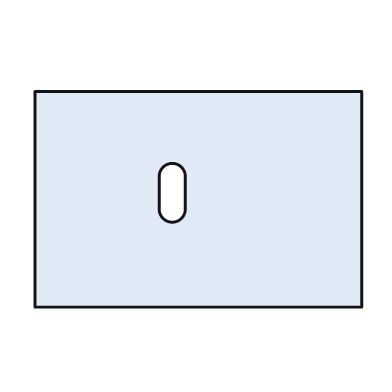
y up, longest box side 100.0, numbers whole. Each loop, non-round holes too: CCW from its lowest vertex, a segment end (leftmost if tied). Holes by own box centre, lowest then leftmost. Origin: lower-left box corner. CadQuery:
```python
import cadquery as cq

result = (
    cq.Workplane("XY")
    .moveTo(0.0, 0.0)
    .lineTo(100.0, 0.0)
    .lineTo(100.0, 66.0)
    .lineTo(0.0, 66.0)
    .close()
    .moveTo(38.0, 30.0)
    .threePointArc((42.0, 26.0), (46.0, 30.0))
    .lineTo(46.0, 40.0)
    .threePointArc((42.0, 44.0), (38.0, 40.0))
    .close()
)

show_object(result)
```